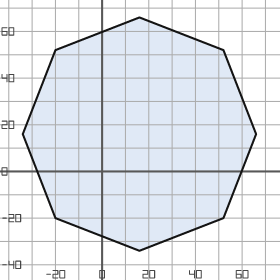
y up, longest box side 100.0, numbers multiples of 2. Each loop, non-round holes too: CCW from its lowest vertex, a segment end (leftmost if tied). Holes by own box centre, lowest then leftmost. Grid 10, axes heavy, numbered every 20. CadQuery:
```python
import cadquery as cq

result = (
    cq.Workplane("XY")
    .moveTo(16.0, -34.0)
    .lineTo(52.0, -20.0)
    .lineTo(66.0, 16.0)
    .lineTo(52.0, 52.0)
    .lineTo(16.0, 66.0)
    .lineTo(-20.0, 52.0)
    .lineTo(-34.0, 16.0)
    .lineTo(-20.0, -20.0)
    .close()
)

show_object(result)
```